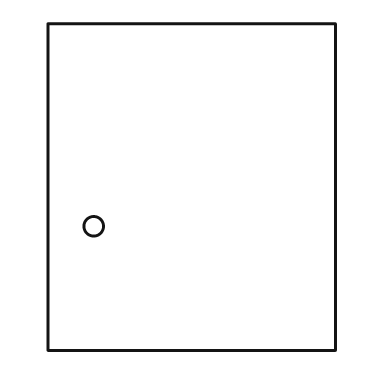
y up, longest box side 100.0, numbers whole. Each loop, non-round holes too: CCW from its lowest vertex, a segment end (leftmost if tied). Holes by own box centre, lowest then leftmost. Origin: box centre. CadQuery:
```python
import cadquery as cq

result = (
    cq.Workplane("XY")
    .moveTo(-44.0, -50.0)
    .lineTo(44.0, -50.0)
    .lineTo(44.0, 50.0)
    .lineTo(-44.0, 50.0)
    .close()
    .moveTo(-30.0, -12.0)
    .circle(3.0)
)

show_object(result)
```